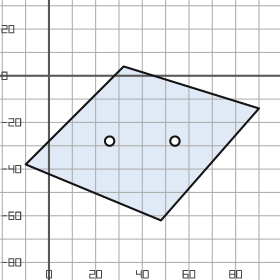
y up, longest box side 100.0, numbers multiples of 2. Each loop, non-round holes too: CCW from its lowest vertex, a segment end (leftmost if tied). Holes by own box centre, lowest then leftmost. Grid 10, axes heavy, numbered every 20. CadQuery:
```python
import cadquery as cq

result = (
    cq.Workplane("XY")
    .moveTo(48.0, -62.0)
    .lineTo(90.0, -14.0)
    .lineTo(32.0, 4.0)
    .lineTo(-10.0, -38.0)
    .close()
    .moveTo(26.0, -28.0)
    .circle(2.0)
    .moveTo(54.0, -28.0)
    .circle(2.0)
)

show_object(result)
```